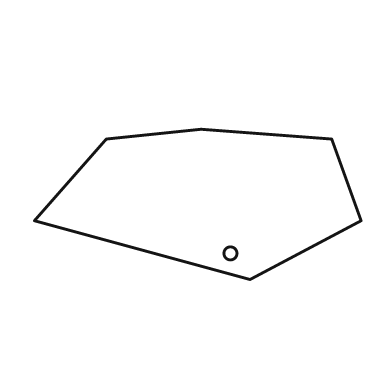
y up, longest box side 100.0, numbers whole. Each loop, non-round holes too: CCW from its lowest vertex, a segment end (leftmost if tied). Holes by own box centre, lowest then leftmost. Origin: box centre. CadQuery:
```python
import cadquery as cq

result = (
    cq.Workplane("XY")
    .moveTo(16.0, -23.0)
    .lineTo(50.0, -5.0)
    .lineTo(41.0, 20.0)
    .lineTo(1.0, 23.0)
    .lineTo(-28.0, 20.0)
    .lineTo(-50.0, -5.0)
    .close()
    .moveTo(10.0, -15.0)
    .circle(2.0)
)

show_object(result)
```